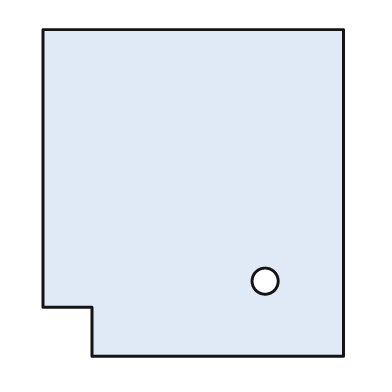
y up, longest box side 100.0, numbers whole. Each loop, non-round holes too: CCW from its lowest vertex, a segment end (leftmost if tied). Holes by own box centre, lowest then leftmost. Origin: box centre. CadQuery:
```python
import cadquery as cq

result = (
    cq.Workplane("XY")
    .moveTo(-31.0, -50.0)
    .lineTo(46.0, -50.0)
    .lineTo(46.0, 50.0)
    .lineTo(-46.0, 50.0)
    .lineTo(-46.0, -35.0)
    .lineTo(-31.0, -35.0)
    .close()
    .moveTo(22.0, -27.0)
    .circle(4.0)
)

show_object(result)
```